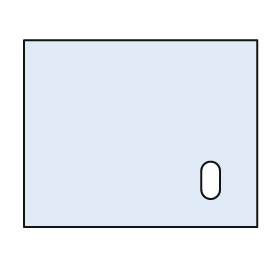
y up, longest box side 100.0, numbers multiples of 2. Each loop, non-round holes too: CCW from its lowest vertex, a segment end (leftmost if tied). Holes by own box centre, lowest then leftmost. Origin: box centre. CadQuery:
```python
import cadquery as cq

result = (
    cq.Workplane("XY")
    .moveTo(-50.0, -40.0)
    .lineTo(50.0, -40.0)
    .lineTo(50.0, 40.0)
    .lineTo(-50.0, 40.0)
    .close()
    .moveTo(26.0, -24.0)
    .threePointArc((30.0, -28.0), (34.0, -24.0))
    .lineTo(34.0, -16.0)
    .threePointArc((30.0, -12.0), (26.0, -16.0))
    .close()
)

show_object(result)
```